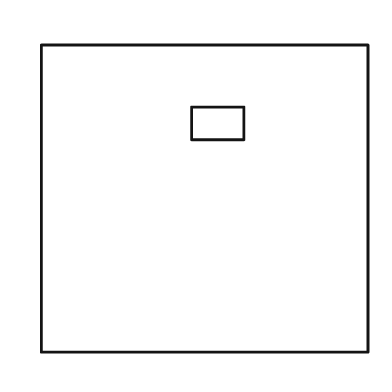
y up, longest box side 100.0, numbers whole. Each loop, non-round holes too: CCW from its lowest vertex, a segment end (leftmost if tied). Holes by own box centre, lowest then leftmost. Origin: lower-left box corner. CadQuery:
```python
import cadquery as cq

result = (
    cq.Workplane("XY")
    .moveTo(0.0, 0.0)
    .lineTo(100.0, 0.0)
    .lineTo(100.0, 94.0)
    .lineTo(0.0, 94.0)
    .close()
    .moveTo(46.0, 65.0)
    .lineTo(62.0, 65.0)
    .lineTo(62.0, 75.0)
    .lineTo(46.0, 75.0)
    .close()
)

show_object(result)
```